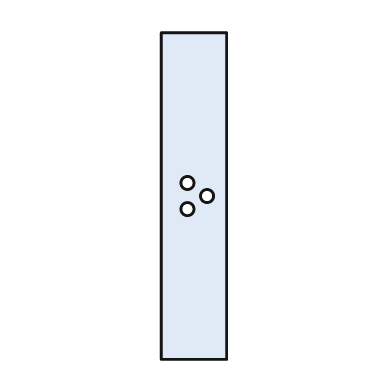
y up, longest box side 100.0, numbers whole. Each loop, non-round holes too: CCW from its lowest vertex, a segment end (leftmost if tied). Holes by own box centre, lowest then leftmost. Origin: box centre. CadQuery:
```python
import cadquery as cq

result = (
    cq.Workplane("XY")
    .moveTo(-10.0, -50.0)
    .lineTo(10.0, -50.0)
    .lineTo(10.0, 50.0)
    .lineTo(-10.0, 50.0)
    .close()
    .moveTo(-2.0, -4.0)
    .circle(2.0)
    .moveTo(4.0, 0.0)
    .circle(2.0)
    .moveTo(-2.0, 4.0)
    .circle(2.0)
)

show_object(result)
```